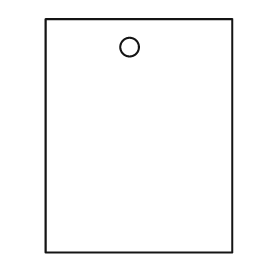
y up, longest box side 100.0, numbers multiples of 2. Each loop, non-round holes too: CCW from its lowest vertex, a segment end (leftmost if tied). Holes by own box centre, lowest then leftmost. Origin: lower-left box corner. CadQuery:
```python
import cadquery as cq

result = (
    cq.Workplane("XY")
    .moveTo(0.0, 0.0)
    .lineTo(80.0, 0.0)
    .lineTo(80.0, 100.0)
    .lineTo(0.0, 100.0)
    .close()
    .moveTo(36.0, 88.0)
    .circle(4.0)
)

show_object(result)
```